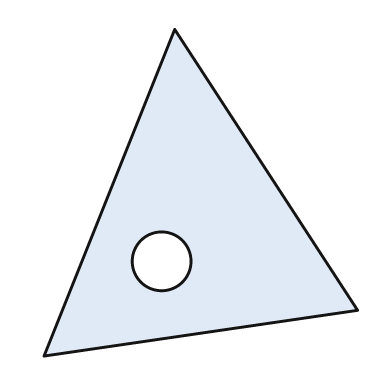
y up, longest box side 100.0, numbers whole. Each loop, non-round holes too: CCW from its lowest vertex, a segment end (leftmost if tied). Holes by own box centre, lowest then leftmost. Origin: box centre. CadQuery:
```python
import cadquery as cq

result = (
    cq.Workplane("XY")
    .moveTo(-48.0, -50.0)
    .lineTo(48.0, -36.0)
    .lineTo(-8.0, 50.0)
    .close()
    .moveTo(-12.0, -21.0)
    .circle(9.0)
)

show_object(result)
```